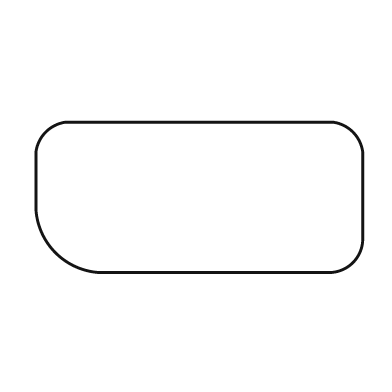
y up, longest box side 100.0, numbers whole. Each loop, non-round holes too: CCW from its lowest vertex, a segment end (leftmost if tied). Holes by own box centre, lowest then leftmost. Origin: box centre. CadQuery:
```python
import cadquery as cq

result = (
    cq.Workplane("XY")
    .moveTo(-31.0, -23.0)
    .lineTo(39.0, -23.0)
    .threePointArc((47.0, -20.0), (50.0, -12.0))
    .lineTo(50.0, 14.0)
    .threePointArc((47.0, 20.0), (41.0, 23.0))
    .lineTo(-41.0, 23.0)
    .threePointArc((-47.0, 20.0), (-50.0, 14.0))
    .lineTo(-50.0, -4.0)
    .threePointArc((-44.0, -17.0), (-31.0, -23.0))
    .close()
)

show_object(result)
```